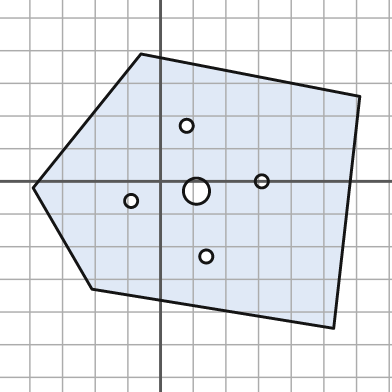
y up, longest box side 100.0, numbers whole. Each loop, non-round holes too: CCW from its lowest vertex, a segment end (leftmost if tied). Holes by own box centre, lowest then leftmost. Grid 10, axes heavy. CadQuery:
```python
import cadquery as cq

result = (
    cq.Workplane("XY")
    .moveTo(53.0, -45.0)
    .lineTo(61.0, 26.0)
    .lineTo(-6.0, 39.0)
    .lineTo(-39.0, -2.0)
    .lineTo(-21.0, -33.0)
    .close()
    .moveTo(14.0, -23.0)
    .circle(2.0)
    .moveTo(-9.0, -6.0)
    .circle(2.0)
    .moveTo(11.0, -3.0)
    .circle(4.0)
    .moveTo(31.0, 0.0)
    .circle(2.0)
    .moveTo(8.0, 17.0)
    .circle(2.0)
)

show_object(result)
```